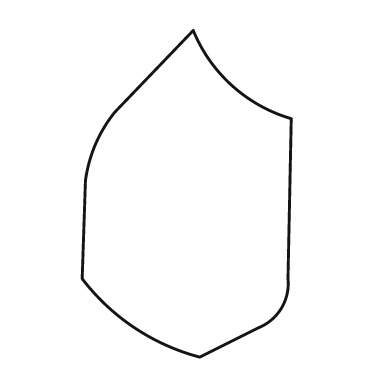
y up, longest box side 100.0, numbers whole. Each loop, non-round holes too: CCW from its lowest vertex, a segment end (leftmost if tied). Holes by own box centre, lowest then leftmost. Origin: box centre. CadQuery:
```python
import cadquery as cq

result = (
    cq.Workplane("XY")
    .moveTo(4.0, -50.0)
    .lineTo(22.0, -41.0)
    .threePointArc((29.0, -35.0), (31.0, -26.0))
    .lineTo(32.0, 23.0)
    .threePointArc((14.0, 33.0), (2.0, 50.0))
    .lineTo(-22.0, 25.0)
    .threePointArc((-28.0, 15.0), (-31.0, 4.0))
    .lineTo(-32.0, -26.0)
    .threePointArc((-16.0, -41.0), (4.0, -50.0))
    .close()
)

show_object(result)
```